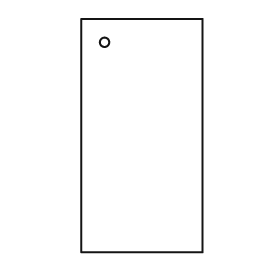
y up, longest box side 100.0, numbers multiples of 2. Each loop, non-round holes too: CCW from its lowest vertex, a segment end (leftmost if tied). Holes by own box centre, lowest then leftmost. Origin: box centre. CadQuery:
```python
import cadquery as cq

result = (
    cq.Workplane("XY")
    .moveTo(-26.0, -50.0)
    .lineTo(26.0, -50.0)
    .lineTo(26.0, 50.0)
    .lineTo(-26.0, 50.0)
    .close()
    .moveTo(-16.0, 40.0)
    .circle(2.0)
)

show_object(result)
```